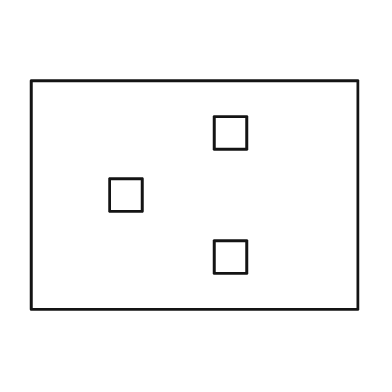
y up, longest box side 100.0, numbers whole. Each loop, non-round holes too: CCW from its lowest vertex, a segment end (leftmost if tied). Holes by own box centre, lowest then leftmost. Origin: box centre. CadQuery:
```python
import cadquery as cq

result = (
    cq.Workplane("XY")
    .moveTo(-50.0, -35.0)
    .lineTo(50.0, -35.0)
    .lineTo(50.0, 35.0)
    .lineTo(-50.0, 35.0)
    .close()
    .moveTo(6.0, -24.0)
    .lineTo(16.0, -24.0)
    .lineTo(16.0, -14.0)
    .lineTo(6.0, -14.0)
    .close()
    .moveTo(-26.0, -5.0)
    .lineTo(-16.0, -5.0)
    .lineTo(-16.0, 5.0)
    .lineTo(-26.0, 5.0)
    .close()
    .moveTo(6.0, 14.0)
    .lineTo(16.0, 14.0)
    .lineTo(16.0, 24.0)
    .lineTo(6.0, 24.0)
    .close()
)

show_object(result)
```